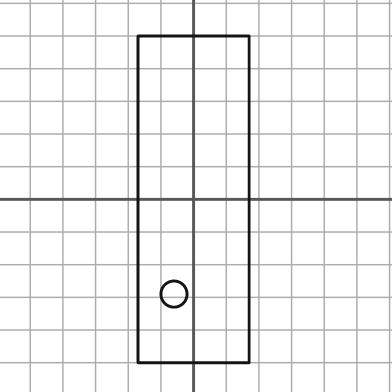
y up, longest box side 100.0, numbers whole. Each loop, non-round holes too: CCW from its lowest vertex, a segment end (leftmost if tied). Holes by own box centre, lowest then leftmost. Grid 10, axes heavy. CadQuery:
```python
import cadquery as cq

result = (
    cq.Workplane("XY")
    .moveTo(-17.0, -50.0)
    .lineTo(17.0, -50.0)
    .lineTo(17.0, 50.0)
    .lineTo(-17.0, 50.0)
    .close()
    .moveTo(-6.0, -29.0)
    .circle(4.0)
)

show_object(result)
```